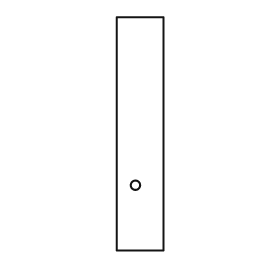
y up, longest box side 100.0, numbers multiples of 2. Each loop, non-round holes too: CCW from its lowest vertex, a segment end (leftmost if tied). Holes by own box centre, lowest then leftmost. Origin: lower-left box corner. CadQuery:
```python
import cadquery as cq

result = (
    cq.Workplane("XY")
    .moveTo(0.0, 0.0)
    .lineTo(20.0, 0.0)
    .lineTo(20.0, 100.0)
    .lineTo(0.0, 100.0)
    .close()
    .moveTo(8.0, 28.0)
    .circle(2.0)
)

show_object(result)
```